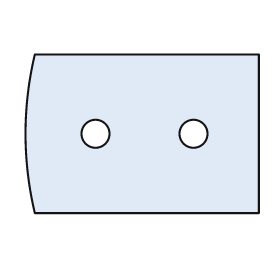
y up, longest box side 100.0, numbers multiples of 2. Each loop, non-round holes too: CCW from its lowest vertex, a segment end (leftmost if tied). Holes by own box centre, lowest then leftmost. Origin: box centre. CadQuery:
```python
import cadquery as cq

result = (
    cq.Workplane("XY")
    .moveTo(-46.0, -34.0)
    .lineTo(50.0, -34.0)
    .lineTo(50.0, 34.0)
    .lineTo(-46.0, 34.0)
    .threePointArc((-50.0, 0.0), (-46.0, -34.0))
    .close()
    .moveTo(-20.0, 0.0)
    .circle(6.0)
    .moveTo(22.0, 0.0)
    .circle(6.0)
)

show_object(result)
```